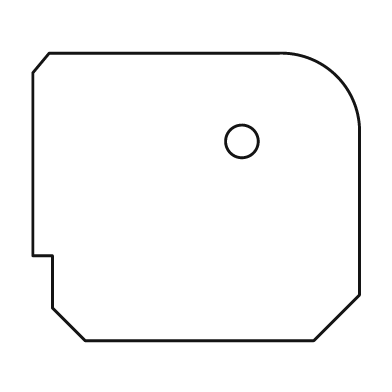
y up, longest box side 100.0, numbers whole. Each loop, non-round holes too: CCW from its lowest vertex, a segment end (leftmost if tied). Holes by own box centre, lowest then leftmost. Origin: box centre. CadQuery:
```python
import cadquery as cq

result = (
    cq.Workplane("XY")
    .moveTo(-34.0, -44.0)
    .lineTo(36.0, -44.0)
    .lineTo(50.0, -30.0)
    .lineTo(50.0, 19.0)
    .threePointArc((43.0, 37.0), (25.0, 44.0))
    .lineTo(-45.0, 44.0)
    .lineTo(-50.0, 38.0)
    .lineTo(-50.0, -18.0)
    .lineTo(-44.0, -18.0)
    .lineTo(-44.0, -34.0)
    .close()
    .moveTo(14.0, 17.0)
    .circle(5.0)
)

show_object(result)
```